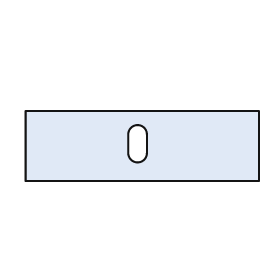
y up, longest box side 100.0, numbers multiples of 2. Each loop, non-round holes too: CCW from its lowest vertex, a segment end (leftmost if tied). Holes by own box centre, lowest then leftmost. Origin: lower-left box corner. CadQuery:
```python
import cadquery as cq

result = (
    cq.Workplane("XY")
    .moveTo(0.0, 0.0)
    .lineTo(100.0, 0.0)
    .lineTo(100.0, 30.0)
    .lineTo(0.0, 30.0)
    .close()
    .moveTo(44.0, 12.0)
    .threePointArc((48.0, 8.0), (52.0, 12.0))
    .lineTo(52.0, 20.0)
    .threePointArc((48.0, 24.0), (44.0, 20.0))
    .close()
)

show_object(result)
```